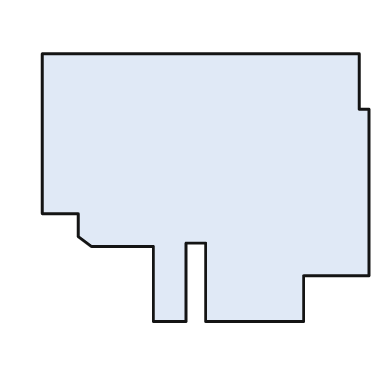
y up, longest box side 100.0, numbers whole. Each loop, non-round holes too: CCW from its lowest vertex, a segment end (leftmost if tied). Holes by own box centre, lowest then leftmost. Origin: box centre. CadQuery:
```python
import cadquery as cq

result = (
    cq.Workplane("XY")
    .moveTo(-16.0, -41.0)
    .lineTo(-6.0, -41.0)
    .lineTo(-6.0, -17.0)
    .lineTo(0.0, -17.0)
    .lineTo(0.0, -41.0)
    .lineTo(30.0, -41.0)
    .lineTo(30.0, -27.0)
    .lineTo(50.0, -27.0)
    .lineTo(50.0, 24.0)
    .lineTo(47.0, 24.0)
    .lineTo(47.0, 41.0)
    .lineTo(-50.0, 41.0)
    .lineTo(-50.0, -8.0)
    .lineTo(-39.0, -8.0)
    .lineTo(-39.0, -15.0)
    .lineTo(-35.0, -18.0)
    .lineTo(-16.0, -18.0)
    .close()
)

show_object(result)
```